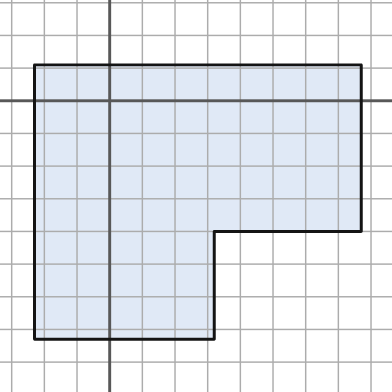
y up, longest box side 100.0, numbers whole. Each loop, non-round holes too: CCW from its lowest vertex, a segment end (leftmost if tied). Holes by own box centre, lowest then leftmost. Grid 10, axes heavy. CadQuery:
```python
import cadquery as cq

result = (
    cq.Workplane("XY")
    .moveTo(-23.0, -73.0)
    .lineTo(32.0, -73.0)
    .lineTo(32.0, -40.0)
    .lineTo(77.0, -40.0)
    .lineTo(77.0, 11.0)
    .lineTo(-23.0, 11.0)
    .close()
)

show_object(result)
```